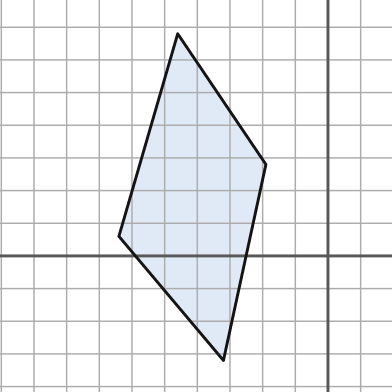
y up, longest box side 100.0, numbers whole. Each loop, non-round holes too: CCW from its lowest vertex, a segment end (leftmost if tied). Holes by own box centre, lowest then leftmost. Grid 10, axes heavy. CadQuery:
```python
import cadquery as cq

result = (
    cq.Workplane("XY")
    .moveTo(-32.0, -32.0)
    .lineTo(-19.0, 28.0)
    .lineTo(-46.0, 68.0)
    .lineTo(-64.0, 6.0)
    .close()
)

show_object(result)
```